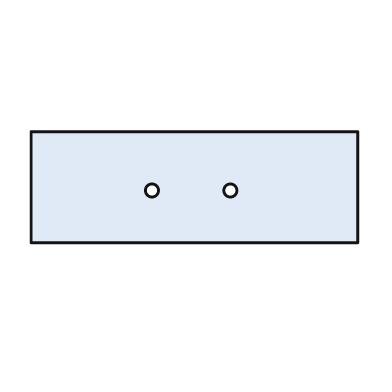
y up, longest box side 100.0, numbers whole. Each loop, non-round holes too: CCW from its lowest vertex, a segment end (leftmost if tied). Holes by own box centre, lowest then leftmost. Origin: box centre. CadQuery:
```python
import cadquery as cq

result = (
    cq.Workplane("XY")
    .moveTo(-50.0, -17.0)
    .lineTo(50.0, -17.0)
    .lineTo(50.0, 17.0)
    .lineTo(-50.0, 17.0)
    .close()
    .moveTo(-13.0, -1.0)
    .circle(2.0)
    .moveTo(11.0, -1.0)
    .circle(2.0)
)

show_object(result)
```